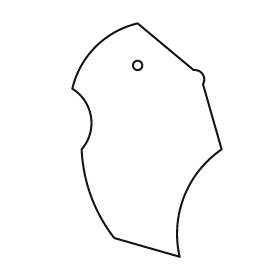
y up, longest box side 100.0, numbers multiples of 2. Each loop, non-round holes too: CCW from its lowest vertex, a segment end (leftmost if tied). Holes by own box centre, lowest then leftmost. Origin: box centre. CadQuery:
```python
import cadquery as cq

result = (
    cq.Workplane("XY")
    .moveTo(14.0, -50.0)
    .threePointArc((16.0, -24.0), (32.0, -4.0))
    .lineTo(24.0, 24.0)
    .threePointArc((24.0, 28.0), (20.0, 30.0))
    .lineTo(-4.0, 50.0)
    .threePointArc((-22.0, 40.0), (-32.0, 22.0))
    .threePointArc((-24.0, 10.0), (-28.0, -4.0))
    .threePointArc((-24.0, -24.0), (-14.0, -42.0))
    .close()
    .moveTo(-4.0, 32.0)
    .circle(2.0)
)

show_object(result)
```